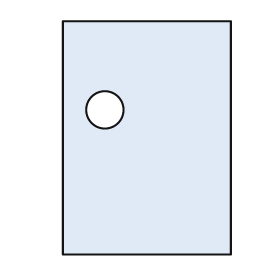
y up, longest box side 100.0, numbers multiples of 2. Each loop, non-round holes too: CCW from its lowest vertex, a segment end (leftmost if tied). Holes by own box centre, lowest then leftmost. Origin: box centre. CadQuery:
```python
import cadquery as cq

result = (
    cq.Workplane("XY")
    .moveTo(-36.0, -50.0)
    .lineTo(36.0, -50.0)
    .lineTo(36.0, 50.0)
    .lineTo(-36.0, 50.0)
    .close()
    .moveTo(-18.0, 12.0)
    .circle(8.0)
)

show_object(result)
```